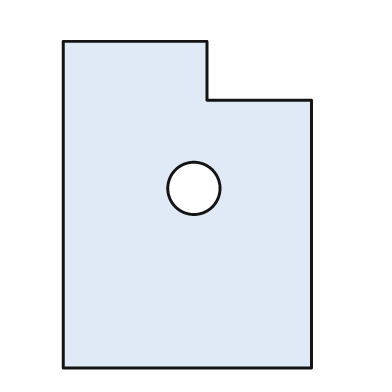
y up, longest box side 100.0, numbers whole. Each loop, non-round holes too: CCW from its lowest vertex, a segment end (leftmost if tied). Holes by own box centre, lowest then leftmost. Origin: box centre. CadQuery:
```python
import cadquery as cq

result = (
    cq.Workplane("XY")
    .moveTo(-38.0, -50.0)
    .lineTo(38.0, -50.0)
    .lineTo(38.0, 32.0)
    .lineTo(6.0, 32.0)
    .lineTo(6.0, 50.0)
    .lineTo(-38.0, 50.0)
    .close()
    .moveTo(2.0, 5.0)
    .circle(8.0)
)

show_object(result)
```